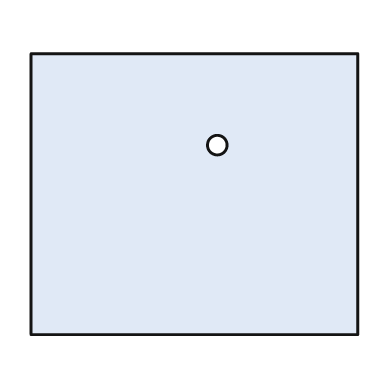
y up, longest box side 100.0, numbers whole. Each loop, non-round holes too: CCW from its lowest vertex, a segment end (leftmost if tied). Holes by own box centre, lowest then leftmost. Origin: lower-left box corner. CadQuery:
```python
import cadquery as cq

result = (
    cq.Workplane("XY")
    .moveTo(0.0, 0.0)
    .lineTo(100.0, 0.0)
    .lineTo(100.0, 86.0)
    .lineTo(0.0, 86.0)
    .close()
    .moveTo(57.0, 58.0)
    .circle(3.0)
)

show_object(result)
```